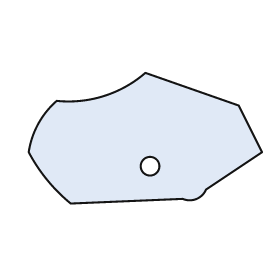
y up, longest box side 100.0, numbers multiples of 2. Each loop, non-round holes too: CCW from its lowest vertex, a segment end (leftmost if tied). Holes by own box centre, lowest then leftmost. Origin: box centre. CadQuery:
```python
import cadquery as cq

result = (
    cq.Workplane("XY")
    .moveTo(-32.0, -28.0)
    .lineTo(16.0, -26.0)
    .threePointArc((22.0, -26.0), (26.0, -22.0))
    .lineTo(50.0, -6.0)
    .lineTo(40.0, 14.0)
    .lineTo(0.0, 28.0)
    .threePointArc((-18.0, 18.0), (-38.0, 16.0))
    .threePointArc((-46.0, 6.0), (-50.0, -6.0))
    .threePointArc((-42.0, -18.0), (-32.0, -28.0))
    .close()
    .moveTo(2.0, -12.0)
    .circle(4.0)
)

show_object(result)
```